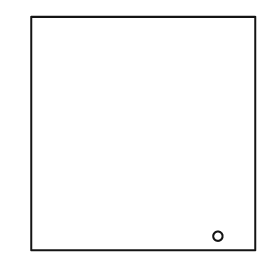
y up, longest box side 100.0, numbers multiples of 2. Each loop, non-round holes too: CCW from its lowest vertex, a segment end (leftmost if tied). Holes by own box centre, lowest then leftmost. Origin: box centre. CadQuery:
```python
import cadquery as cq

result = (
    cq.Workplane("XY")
    .moveTo(-48.0, -50.0)
    .lineTo(48.0, -50.0)
    .lineTo(48.0, 50.0)
    .lineTo(-48.0, 50.0)
    .close()
    .moveTo(32.0, -44.0)
    .circle(2.0)
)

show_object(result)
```